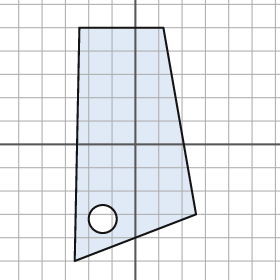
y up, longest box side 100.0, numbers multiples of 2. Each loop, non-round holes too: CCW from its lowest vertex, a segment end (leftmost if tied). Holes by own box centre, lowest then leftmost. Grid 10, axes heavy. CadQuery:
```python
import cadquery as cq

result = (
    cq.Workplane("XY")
    .moveTo(-26.0, -50.0)
    .lineTo(26.0, -30.0)
    .lineTo(12.0, 50.0)
    .lineTo(-24.0, 50.0)
    .close()
    .moveTo(-14.0, -32.0)
    .circle(6.0)
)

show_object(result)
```